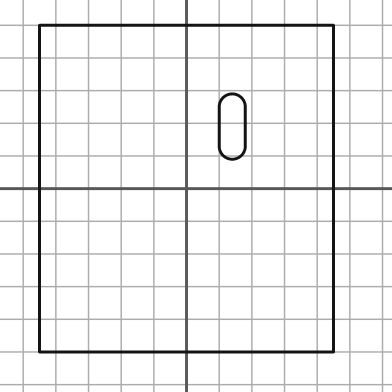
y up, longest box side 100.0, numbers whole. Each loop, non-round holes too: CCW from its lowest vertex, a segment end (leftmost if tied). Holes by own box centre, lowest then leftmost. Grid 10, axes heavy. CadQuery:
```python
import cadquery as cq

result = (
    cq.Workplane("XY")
    .moveTo(-45.0, -50.0)
    .lineTo(45.0, -50.0)
    .lineTo(45.0, 50.0)
    .lineTo(-45.0, 50.0)
    .close()
    .moveTo(10.0, 13.0)
    .threePointArc((14.0, 9.0), (18.0, 13.0))
    .lineTo(18.0, 25.0)
    .threePointArc((14.0, 29.0), (10.0, 25.0))
    .close()
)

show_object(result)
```